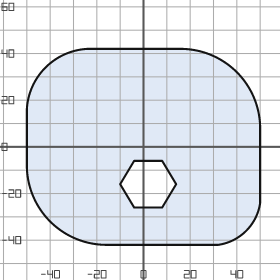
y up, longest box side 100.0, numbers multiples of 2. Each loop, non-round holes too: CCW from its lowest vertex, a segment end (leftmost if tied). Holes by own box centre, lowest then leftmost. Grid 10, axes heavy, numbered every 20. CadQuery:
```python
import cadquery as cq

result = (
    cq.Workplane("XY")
    .moveTo(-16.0, -42.0)
    .lineTo(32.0, -42.0)
    .threePointArc((44.0, -36.0), (50.0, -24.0))
    .lineTo(50.0, 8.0)
    .threePointArc((40.0, 32.0), (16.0, 42.0))
    .lineTo(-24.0, 42.0)
    .threePointArc((-42.0, 34.0), (-50.0, 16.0))
    .lineTo(-50.0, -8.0)
    .threePointArc((-40.0, -32.0), (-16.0, -42.0))
    .close()
    .moveTo(-4.0, -26.0)
    .lineTo(8.0, -26.0)
    .lineTo(14.0, -16.0)
    .lineTo(8.0, -6.0)
    .lineTo(-4.0, -6.0)
    .lineTo(-10.0, -16.0)
    .close()
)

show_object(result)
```